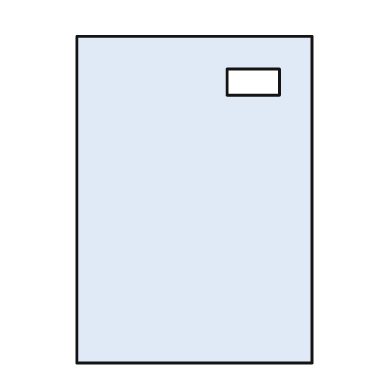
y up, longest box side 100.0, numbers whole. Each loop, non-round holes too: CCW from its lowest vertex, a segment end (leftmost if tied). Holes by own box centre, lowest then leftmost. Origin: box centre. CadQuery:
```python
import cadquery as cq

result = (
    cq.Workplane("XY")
    .moveTo(-36.0, -50.0)
    .lineTo(36.0, -50.0)
    .lineTo(36.0, 50.0)
    .lineTo(-36.0, 50.0)
    .close()
    .moveTo(10.0, 32.0)
    .lineTo(26.0, 32.0)
    .lineTo(26.0, 40.0)
    .lineTo(10.0, 40.0)
    .close()
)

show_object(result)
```